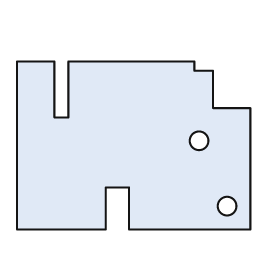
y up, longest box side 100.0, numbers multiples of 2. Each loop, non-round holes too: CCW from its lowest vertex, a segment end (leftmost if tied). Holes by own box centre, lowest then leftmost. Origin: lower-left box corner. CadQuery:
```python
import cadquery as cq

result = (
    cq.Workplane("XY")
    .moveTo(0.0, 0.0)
    .lineTo(38.0, 0.0)
    .lineTo(38.0, 18.0)
    .lineTo(48.0, 18.0)
    .lineTo(48.0, 0.0)
    .lineTo(100.0, 0.0)
    .lineTo(100.0, 52.0)
    .lineTo(84.0, 52.0)
    .lineTo(84.0, 68.0)
    .lineTo(76.0, 68.0)
    .lineTo(76.0, 72.0)
    .lineTo(22.0, 72.0)
    .lineTo(22.0, 48.0)
    .lineTo(16.0, 48.0)
    .lineTo(16.0, 72.0)
    .lineTo(0.0, 72.0)
    .close()
    .moveTo(90.0, 10.0)
    .circle(4.0)
    .moveTo(78.0, 38.0)
    .circle(4.0)
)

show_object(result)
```